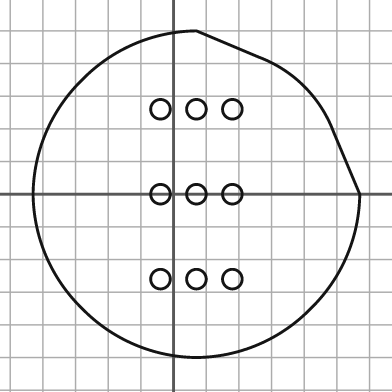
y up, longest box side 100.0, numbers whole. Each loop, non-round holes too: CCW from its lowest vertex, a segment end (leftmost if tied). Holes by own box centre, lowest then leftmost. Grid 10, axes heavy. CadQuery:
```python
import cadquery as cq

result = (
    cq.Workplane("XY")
    .moveTo(7.0, -50.0)
    .threePointArc((26.0, -46.0), (42.0, -35.0))
    .threePointArc((53.0, -19.0), (57.0, 0.0))
    .lineTo(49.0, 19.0)
    .threePointArc((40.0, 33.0), (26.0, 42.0))
    .lineTo(7.0, 50.0)
    .threePointArc((-12.0, 46.0), (-28.0, 35.0))
    .threePointArc((-39.0, 19.0), (-43.0, 0.0))
    .threePointArc((-39.0, -19.0), (-28.0, -35.0))
    .threePointArc((-12.0, -46.0), (7.0, -50.0))
    .close()
    .moveTo(-4.0, -26.0)
    .circle(3.0)
    .moveTo(7.0, -26.0)
    .circle(3.0)
    .moveTo(18.0, -26.0)
    .circle(3.0)
    .moveTo(-4.0, 0.0)
    .circle(3.0)
    .moveTo(7.0, 0.0)
    .circle(3.0)
    .moveTo(18.0, 0.0)
    .circle(3.0)
    .moveTo(-4.0, 26.0)
    .circle(3.0)
    .moveTo(7.0, 26.0)
    .circle(3.0)
    .moveTo(18.0, 26.0)
    .circle(3.0)
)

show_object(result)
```